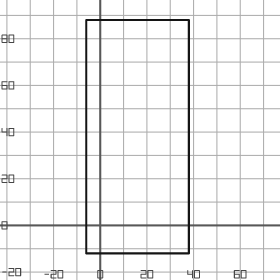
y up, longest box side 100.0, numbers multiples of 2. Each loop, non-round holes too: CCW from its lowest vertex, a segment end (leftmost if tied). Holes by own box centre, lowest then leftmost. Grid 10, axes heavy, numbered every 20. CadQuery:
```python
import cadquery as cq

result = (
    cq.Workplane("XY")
    .moveTo(-6.0, -12.0)
    .lineTo(38.0, -12.0)
    .lineTo(38.0, 88.0)
    .lineTo(-6.0, 88.0)
    .close()
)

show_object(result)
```